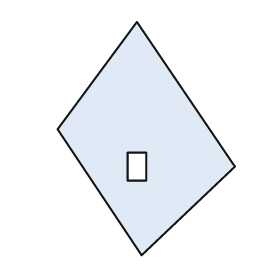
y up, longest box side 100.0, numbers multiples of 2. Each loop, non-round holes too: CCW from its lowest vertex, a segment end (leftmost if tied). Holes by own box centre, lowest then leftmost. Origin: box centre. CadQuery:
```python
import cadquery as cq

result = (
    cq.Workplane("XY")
    .moveTo(-2.0, -50.0)
    .lineTo(38.0, -12.0)
    .lineTo(-4.0, 50.0)
    .lineTo(-38.0, 4.0)
    .close()
    .moveTo(-8.0, -18.0)
    .lineTo(0.0, -18.0)
    .lineTo(0.0, -6.0)
    .lineTo(-8.0, -6.0)
    .close()
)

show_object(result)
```